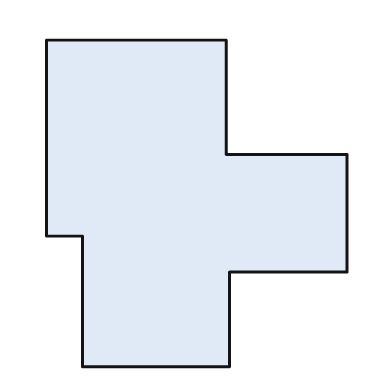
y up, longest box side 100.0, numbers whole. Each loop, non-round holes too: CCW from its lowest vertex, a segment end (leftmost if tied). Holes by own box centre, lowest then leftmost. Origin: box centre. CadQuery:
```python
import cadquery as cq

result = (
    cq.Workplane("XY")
    .moveTo(-35.0, -50.0)
    .lineTo(10.0, -50.0)
    .lineTo(10.0, -21.0)
    .lineTo(46.0, -21.0)
    .lineTo(46.0, 15.0)
    .lineTo(9.0, 15.0)
    .lineTo(9.0, 50.0)
    .lineTo(-46.0, 50.0)
    .lineTo(-46.0, -10.0)
    .lineTo(-35.0, -10.0)
    .close()
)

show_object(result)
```